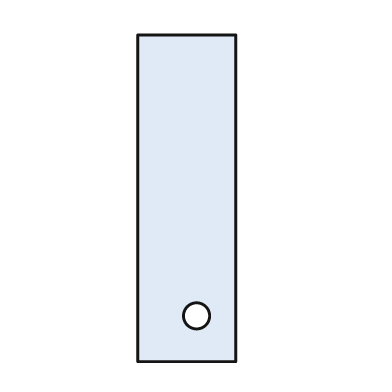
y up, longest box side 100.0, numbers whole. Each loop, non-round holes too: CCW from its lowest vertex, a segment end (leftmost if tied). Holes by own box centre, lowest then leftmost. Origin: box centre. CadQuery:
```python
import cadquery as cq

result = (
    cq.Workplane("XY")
    .moveTo(-15.0, -50.0)
    .lineTo(15.0, -50.0)
    .lineTo(15.0, 50.0)
    .lineTo(-15.0, 50.0)
    .close()
    .moveTo(3.0, -36.0)
    .circle(4.0)
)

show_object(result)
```